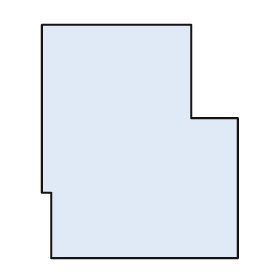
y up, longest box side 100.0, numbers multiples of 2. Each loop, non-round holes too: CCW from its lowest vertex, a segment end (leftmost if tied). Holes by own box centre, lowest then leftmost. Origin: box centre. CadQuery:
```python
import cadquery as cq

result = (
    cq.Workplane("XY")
    .moveTo(-38.0, -50.0)
    .lineTo(42.0, -50.0)
    .lineTo(42.0, 10.0)
    .lineTo(22.0, 10.0)
    .lineTo(22.0, 50.0)
    .lineTo(-42.0, 50.0)
    .lineTo(-42.0, -22.0)
    .lineTo(-38.0, -22.0)
    .close()
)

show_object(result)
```